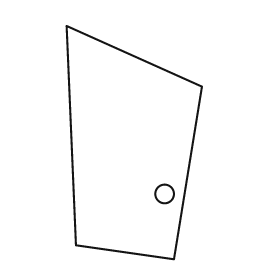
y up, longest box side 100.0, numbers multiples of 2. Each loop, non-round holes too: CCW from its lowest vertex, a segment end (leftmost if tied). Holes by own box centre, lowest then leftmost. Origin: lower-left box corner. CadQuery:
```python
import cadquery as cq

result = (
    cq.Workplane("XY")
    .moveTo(46.0, 0.0)
    .lineTo(58.0, 74.0)
    .lineTo(0.0, 100.0)
    .lineTo(4.0, 6.0)
    .close()
    .moveTo(42.0, 28.0)
    .circle(4.0)
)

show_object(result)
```